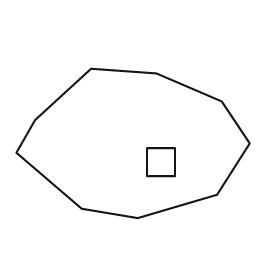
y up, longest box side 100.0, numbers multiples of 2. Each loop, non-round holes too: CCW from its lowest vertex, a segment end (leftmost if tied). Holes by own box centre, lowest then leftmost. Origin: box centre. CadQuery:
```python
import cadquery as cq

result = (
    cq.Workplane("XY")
    .moveTo(2.0, -32.0)
    .lineTo(36.0, -22.0)
    .lineTo(50.0, 0.0)
    .lineTo(38.0, 18.0)
    .lineTo(10.0, 30.0)
    .lineTo(-18.0, 32.0)
    .lineTo(-42.0, 10.0)
    .lineTo(-50.0, -4.0)
    .lineTo(-22.0, -28.0)
    .close()
    .moveTo(6.0, -14.0)
    .lineTo(18.0, -14.0)
    .lineTo(18.0, -2.0)
    .lineTo(6.0, -2.0)
    .close()
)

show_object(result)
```